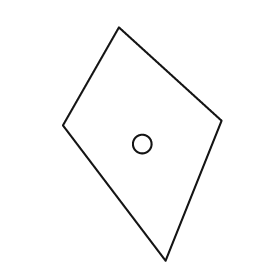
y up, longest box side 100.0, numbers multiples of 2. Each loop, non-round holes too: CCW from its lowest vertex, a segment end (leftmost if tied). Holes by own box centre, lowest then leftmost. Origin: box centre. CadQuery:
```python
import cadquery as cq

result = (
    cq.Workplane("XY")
    .moveTo(10.0, -50.0)
    .lineTo(34.0, 10.0)
    .lineTo(-10.0, 50.0)
    .lineTo(-34.0, 8.0)
    .close()
    .moveTo(0.0, 0.0)
    .circle(4.0)
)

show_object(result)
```